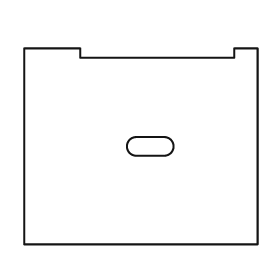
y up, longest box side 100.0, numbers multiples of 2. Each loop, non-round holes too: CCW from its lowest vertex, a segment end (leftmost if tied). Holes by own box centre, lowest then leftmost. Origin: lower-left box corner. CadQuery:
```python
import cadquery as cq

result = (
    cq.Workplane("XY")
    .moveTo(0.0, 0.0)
    .lineTo(100.0, 0.0)
    .lineTo(100.0, 84.0)
    .lineTo(90.0, 84.0)
    .lineTo(90.0, 80.0)
    .lineTo(24.0, 80.0)
    .lineTo(24.0, 84.0)
    .lineTo(0.0, 84.0)
    .close()
    .moveTo(48.0, 38.0)
    .lineTo(60.0, 38.0)
    .threePointArc((64.0, 42.0), (60.0, 46.0))
    .lineTo(48.0, 46.0)
    .threePointArc((44.0, 42.0), (48.0, 38.0))
    .close()
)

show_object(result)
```